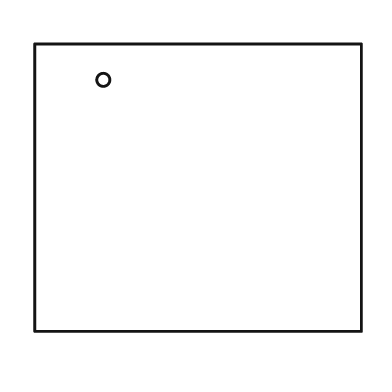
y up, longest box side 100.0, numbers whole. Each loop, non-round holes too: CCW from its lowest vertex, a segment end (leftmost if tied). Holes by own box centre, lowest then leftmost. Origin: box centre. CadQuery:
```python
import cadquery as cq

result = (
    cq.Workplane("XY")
    .moveTo(-50.0, -44.0)
    .lineTo(50.0, -44.0)
    .lineTo(50.0, 44.0)
    .lineTo(-50.0, 44.0)
    .close()
    .moveTo(-29.0, 33.0)
    .circle(2.0)
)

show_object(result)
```